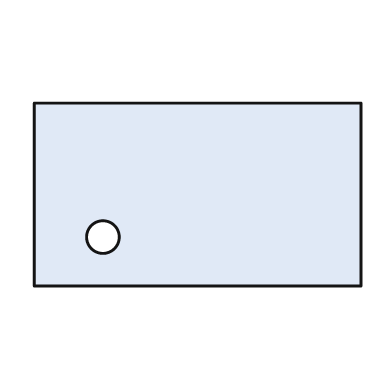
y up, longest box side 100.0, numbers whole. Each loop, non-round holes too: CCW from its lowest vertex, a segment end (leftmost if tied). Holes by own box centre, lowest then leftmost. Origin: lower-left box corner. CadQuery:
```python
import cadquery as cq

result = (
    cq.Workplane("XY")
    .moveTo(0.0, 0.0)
    .lineTo(100.0, 0.0)
    .lineTo(100.0, 56.0)
    .lineTo(0.0, 56.0)
    .close()
    .moveTo(21.0, 15.0)
    .circle(5.0)
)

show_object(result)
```